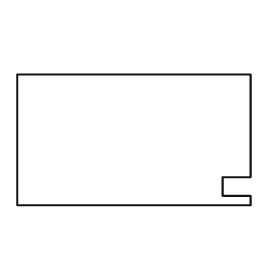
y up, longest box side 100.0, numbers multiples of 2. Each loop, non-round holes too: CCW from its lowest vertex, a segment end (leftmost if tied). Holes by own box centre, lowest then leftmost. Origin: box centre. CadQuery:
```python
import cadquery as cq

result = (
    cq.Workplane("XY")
    .moveTo(-50.0, -28.0)
    .lineTo(50.0, -28.0)
    .lineTo(50.0, -24.0)
    .lineTo(38.0, -24.0)
    .lineTo(38.0, -16.0)
    .lineTo(50.0, -16.0)
    .lineTo(50.0, 28.0)
    .lineTo(-50.0, 28.0)
    .close()
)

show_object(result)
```